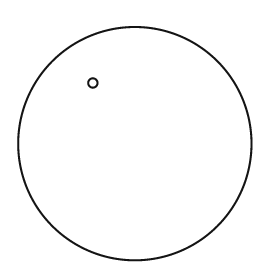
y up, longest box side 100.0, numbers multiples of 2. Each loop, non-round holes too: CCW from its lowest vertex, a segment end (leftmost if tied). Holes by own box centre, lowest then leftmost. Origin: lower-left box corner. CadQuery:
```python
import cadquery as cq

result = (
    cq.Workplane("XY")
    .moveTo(50.0, 50.0)
    .circle(50.0)
    .moveTo(32.0, 76.0)
    .circle(2.0)
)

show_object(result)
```